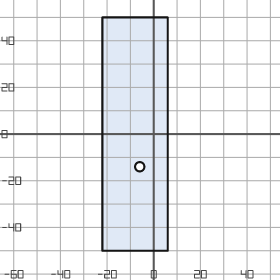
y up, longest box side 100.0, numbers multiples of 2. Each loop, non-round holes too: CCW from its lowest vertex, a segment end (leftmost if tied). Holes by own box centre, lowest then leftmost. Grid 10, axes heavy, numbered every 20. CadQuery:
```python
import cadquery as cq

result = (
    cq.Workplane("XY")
    .moveTo(-22.0, -50.0)
    .lineTo(6.0, -50.0)
    .lineTo(6.0, 50.0)
    .lineTo(-22.0, 50.0)
    .close()
    .moveTo(-6.0, -14.0)
    .circle(2.0)
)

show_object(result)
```